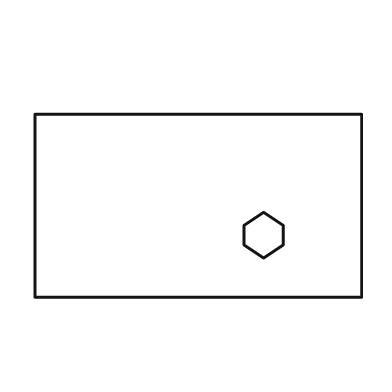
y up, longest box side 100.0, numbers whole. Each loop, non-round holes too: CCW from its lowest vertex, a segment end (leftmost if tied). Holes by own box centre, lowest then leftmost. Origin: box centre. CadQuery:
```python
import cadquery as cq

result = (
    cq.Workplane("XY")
    .moveTo(-50.0, -28.0)
    .lineTo(50.0, -28.0)
    .lineTo(50.0, 28.0)
    .lineTo(-50.0, 28.0)
    .close()
    .moveTo(20.0, -16.0)
    .lineTo(26.0, -12.0)
    .lineTo(26.0, -6.0)
    .lineTo(20.0, -2.0)
    .lineTo(14.0, -6.0)
    .lineTo(14.0, -12.0)
    .close()
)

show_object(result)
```